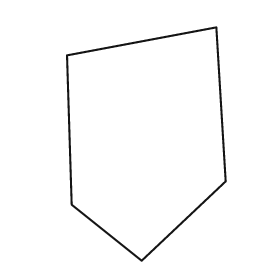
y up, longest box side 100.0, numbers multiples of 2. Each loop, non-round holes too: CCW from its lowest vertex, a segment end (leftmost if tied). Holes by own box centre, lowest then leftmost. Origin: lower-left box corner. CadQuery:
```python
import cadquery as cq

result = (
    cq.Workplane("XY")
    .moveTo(32.0, 0.0)
    .lineTo(68.0, 34.0)
    .lineTo(64.0, 100.0)
    .lineTo(0.0, 88.0)
    .lineTo(2.0, 24.0)
    .close()
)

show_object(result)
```